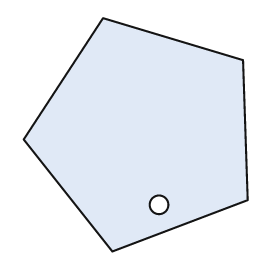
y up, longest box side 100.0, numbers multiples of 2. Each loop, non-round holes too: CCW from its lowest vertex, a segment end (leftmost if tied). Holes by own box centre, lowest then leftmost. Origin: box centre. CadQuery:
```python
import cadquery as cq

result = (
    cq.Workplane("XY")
    .moveTo(-10.0, -50.0)
    .lineTo(48.0, -28.0)
    .lineTo(46.0, 32.0)
    .lineTo(-14.0, 50.0)
    .lineTo(-48.0, -2.0)
    .close()
    .moveTo(10.0, -30.0)
    .circle(4.0)
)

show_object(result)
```